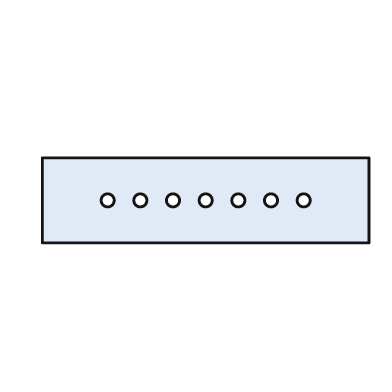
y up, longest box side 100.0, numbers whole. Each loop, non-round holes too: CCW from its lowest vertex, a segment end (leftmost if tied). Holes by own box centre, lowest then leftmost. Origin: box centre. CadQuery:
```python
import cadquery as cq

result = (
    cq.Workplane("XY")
    .moveTo(-50.0, -13.0)
    .lineTo(50.0, -13.0)
    .lineTo(50.0, 13.0)
    .lineTo(-50.0, 13.0)
    .close()
    .moveTo(-30.0, 0.0)
    .circle(2.0)
    .moveTo(-20.0, 0.0)
    .circle(2.0)
    .moveTo(-10.0, 0.0)
    .circle(2.0)
    .moveTo(0.0, 0.0)
    .circle(2.0)
    .moveTo(10.0, 0.0)
    .circle(2.0)
    .moveTo(20.0, 0.0)
    .circle(2.0)
    .moveTo(30.0, 0.0)
    .circle(2.0)
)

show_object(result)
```